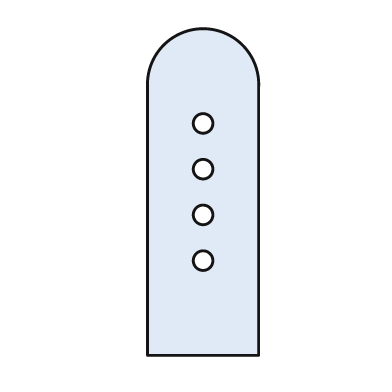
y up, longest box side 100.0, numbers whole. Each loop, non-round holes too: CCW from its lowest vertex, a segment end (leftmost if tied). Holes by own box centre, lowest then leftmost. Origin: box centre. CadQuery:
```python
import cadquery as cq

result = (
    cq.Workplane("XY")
    .moveTo(-17.0, -50.0)
    .lineTo(17.0, -50.0)
    .lineTo(17.0, 32.0)
    .threePointArc((0.0, 50.0), (-17.0, 32.0))
    .close()
    .moveTo(0.0, -21.0)
    .circle(3.0)
    .moveTo(0.0, -7.0)
    .circle(3.0)
    .moveTo(0.0, 7.0)
    .circle(3.0)
    .moveTo(0.0, 21.0)
    .circle(3.0)
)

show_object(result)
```